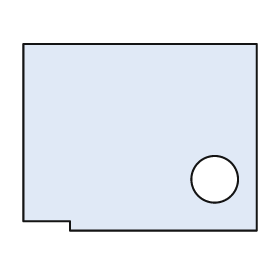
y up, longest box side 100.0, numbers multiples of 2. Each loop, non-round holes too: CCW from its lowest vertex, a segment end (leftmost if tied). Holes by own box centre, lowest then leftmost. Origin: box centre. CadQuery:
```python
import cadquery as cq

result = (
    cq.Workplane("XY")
    .moveTo(-30.0, -40.0)
    .lineTo(50.0, -40.0)
    .lineTo(50.0, 40.0)
    .lineTo(-50.0, 40.0)
    .lineTo(-50.0, -36.0)
    .lineTo(-30.0, -36.0)
    .close()
    .moveTo(32.0, -18.0)
    .circle(10.0)
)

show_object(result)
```